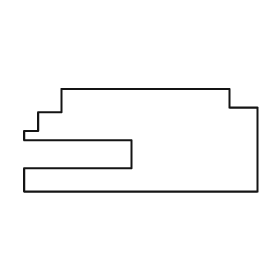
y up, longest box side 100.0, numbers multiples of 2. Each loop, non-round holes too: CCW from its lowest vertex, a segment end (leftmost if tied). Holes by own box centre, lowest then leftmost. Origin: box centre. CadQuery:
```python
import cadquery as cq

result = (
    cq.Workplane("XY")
    .moveTo(-50.0, -22.0)
    .lineTo(50.0, -22.0)
    .lineTo(50.0, 14.0)
    .lineTo(38.0, 14.0)
    .lineTo(38.0, 22.0)
    .lineTo(-34.0, 22.0)
    .lineTo(-34.0, 12.0)
    .lineTo(-44.0, 12.0)
    .lineTo(-44.0, 4.0)
    .lineTo(-50.0, 4.0)
    .lineTo(-50.0, 0.0)
    .lineTo(-4.0, 0.0)
    .lineTo(-4.0, -12.0)
    .lineTo(-50.0, -12.0)
    .close()
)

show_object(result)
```